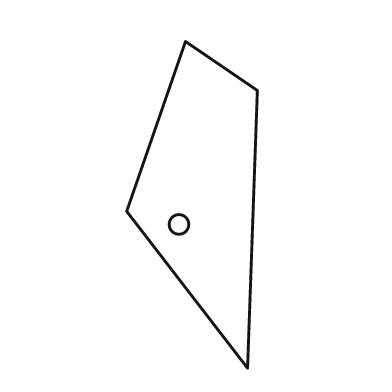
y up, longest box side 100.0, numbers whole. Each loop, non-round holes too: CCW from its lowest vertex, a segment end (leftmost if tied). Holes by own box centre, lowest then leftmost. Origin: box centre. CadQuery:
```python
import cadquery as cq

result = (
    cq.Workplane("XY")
    .moveTo(17.0, -50.0)
    .lineTo(20.0, 35.0)
    .lineTo(-2.0, 50.0)
    .lineTo(-20.0, -2.0)
    .close()
    .moveTo(-4.0, -6.0)
    .circle(3.0)
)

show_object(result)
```